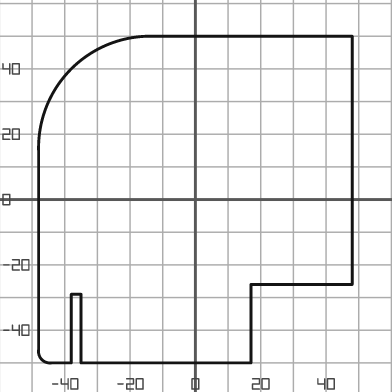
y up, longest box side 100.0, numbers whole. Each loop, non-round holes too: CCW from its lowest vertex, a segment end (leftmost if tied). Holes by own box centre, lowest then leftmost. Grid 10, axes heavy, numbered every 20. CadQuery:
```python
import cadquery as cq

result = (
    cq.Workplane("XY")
    .moveTo(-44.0, -50.0)
    .lineTo(-38.0, -50.0)
    .lineTo(-38.0, -29.0)
    .lineTo(-35.0, -29.0)
    .lineTo(-35.0, -50.0)
    .lineTo(17.0, -50.0)
    .lineTo(17.0, -26.0)
    .lineTo(48.0, -26.0)
    .lineTo(48.0, 50.0)
    .lineTo(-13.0, 50.0)
    .threePointArc((-38.0, 40.0), (-48.0, 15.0))
    .lineTo(-48.0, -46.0)
    .threePointArc((-47.0, -49.0), (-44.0, -50.0))
    .close()
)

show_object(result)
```